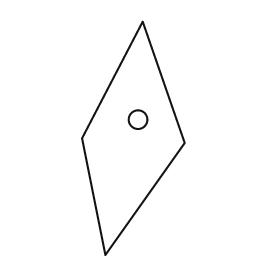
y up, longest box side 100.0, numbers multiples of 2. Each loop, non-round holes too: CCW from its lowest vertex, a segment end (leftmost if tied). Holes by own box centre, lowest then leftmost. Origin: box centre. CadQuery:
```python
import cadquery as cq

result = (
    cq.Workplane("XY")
    .moveTo(-12.0, -50.0)
    .lineTo(22.0, -2.0)
    .lineTo(4.0, 50.0)
    .lineTo(-22.0, 0.0)
    .close()
    .moveTo(2.0, 8.0)
    .circle(4.0)
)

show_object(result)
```